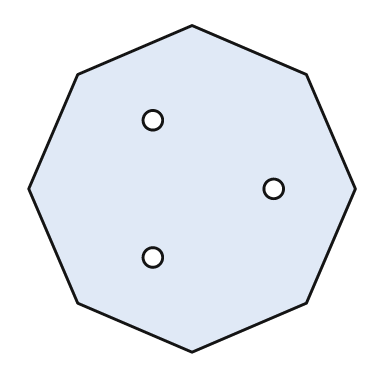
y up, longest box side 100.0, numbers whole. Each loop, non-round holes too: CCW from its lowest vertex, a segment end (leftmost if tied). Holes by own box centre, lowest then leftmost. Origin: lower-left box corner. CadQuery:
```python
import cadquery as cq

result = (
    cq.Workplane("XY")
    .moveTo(50.0, 0.0)
    .lineTo(85.0, 15.0)
    .lineTo(100.0, 50.0)
    .lineTo(85.0, 85.0)
    .lineTo(50.0, 100.0)
    .lineTo(15.0, 85.0)
    .lineTo(0.0, 50.0)
    .lineTo(15.0, 15.0)
    .close()
    .moveTo(38.0, 29.0)
    .circle(3.0)
    .moveTo(75.0, 50.0)
    .circle(3.0)
    .moveTo(38.0, 71.0)
    .circle(3.0)
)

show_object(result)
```